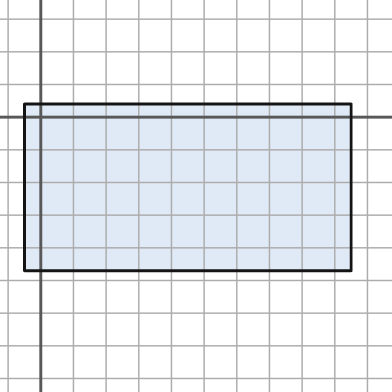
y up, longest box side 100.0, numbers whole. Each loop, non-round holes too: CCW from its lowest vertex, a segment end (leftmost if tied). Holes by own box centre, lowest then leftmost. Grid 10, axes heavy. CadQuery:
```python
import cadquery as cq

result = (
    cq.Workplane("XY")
    .moveTo(-5.0, -47.0)
    .lineTo(95.0, -47.0)
    .lineTo(95.0, 4.0)
    .lineTo(-5.0, 4.0)
    .close()
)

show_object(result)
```